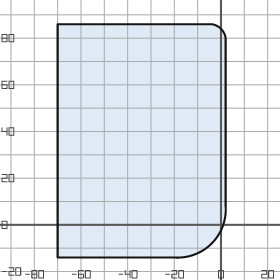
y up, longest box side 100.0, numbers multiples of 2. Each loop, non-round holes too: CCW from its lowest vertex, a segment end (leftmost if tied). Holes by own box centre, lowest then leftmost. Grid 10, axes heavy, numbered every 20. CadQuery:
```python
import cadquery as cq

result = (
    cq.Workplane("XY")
    .moveTo(-70.0, -14.0)
    .lineTo(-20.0, -14.0)
    .threePointArc((-4.0, -8.0), (2.0, 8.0))
    .lineTo(2.0, 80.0)
    .threePointArc((0.0, 84.0), (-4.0, 86.0))
    .lineTo(-70.0, 86.0)
    .close()
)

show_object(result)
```